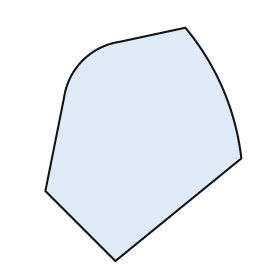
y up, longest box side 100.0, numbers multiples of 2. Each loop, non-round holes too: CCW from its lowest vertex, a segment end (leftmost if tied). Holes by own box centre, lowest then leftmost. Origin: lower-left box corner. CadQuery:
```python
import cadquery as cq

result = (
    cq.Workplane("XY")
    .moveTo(30.0, 0.0)
    .lineTo(84.0, 44.0)
    .threePointArc((76.0, 74.0), (60.0, 100.0))
    .lineTo(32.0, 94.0)
    .threePointArc((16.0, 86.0), (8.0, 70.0))
    .lineTo(0.0, 30.0)
    .close()
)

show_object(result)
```